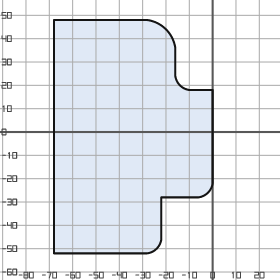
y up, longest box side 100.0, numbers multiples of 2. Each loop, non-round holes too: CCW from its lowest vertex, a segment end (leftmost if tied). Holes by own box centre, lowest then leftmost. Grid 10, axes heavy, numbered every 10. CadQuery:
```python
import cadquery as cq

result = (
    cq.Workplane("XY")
    .moveTo(-68.0, -52.0)
    .lineTo(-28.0, -52.0)
    .threePointArc((-24.0, -50.0), (-22.0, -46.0))
    .lineTo(-22.0, -28.0)
    .lineTo(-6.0, -28.0)
    .threePointArc((-2.0, -26.0), (0.0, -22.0))
    .lineTo(0.0, 18.0)
    .lineTo(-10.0, 18.0)
    .threePointArc((-14.0, 20.0), (-16.0, 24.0))
    .lineTo(-16.0, 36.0)
    .threePointArc((-20.0, 44.0), (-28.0, 48.0))
    .lineTo(-68.0, 48.0)
    .close()
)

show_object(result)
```